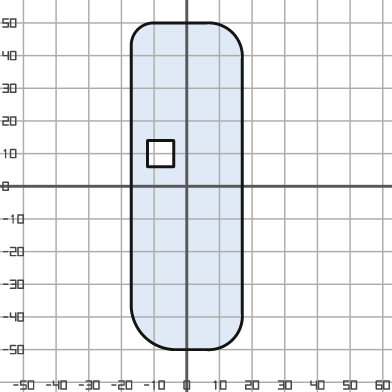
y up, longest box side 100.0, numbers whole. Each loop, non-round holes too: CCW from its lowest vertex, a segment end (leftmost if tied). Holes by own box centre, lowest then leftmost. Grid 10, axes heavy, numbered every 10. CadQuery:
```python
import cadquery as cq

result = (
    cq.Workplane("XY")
    .moveTo(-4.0, -50.0)
    .lineTo(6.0, -50.0)
    .threePointArc((14.0, -47.0), (17.0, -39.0))
    .lineTo(17.0, 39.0)
    .threePointArc((14.0, 47.0), (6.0, 50.0))
    .lineTo(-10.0, 50.0)
    .threePointArc((-15.0, 48.0), (-17.0, 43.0))
    .lineTo(-17.0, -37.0)
    .threePointArc((-13.0, -46.0), (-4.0, -50.0))
    .close()
    .moveTo(-12.0, 6.0)
    .lineTo(-4.0, 6.0)
    .lineTo(-4.0, 14.0)
    .lineTo(-12.0, 14.0)
    .close()
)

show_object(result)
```